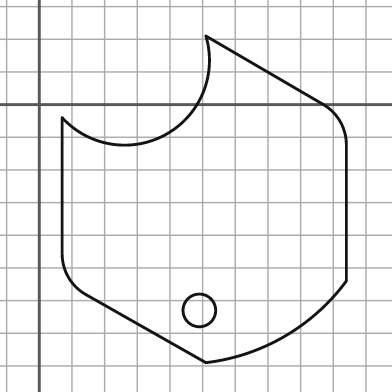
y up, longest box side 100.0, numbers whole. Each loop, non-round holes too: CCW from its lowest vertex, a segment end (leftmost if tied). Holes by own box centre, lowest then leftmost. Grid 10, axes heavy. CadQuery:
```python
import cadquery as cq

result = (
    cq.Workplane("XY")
    .moveTo(51.0, -79.0)
    .threePointArc((75.0, -71.0), (94.0, -54.0))
    .lineTo(94.0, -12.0)
    .threePointArc((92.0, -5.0), (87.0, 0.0))
    .lineTo(51.0, 21.0)
    .threePointArc((39.0, -9.0), (7.0, -4.0))
    .lineTo(7.0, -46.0)
    .threePointArc((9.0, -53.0), (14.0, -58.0))
    .close()
    .moveTo(49.0, -63.0)
    .circle(5.0)
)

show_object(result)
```